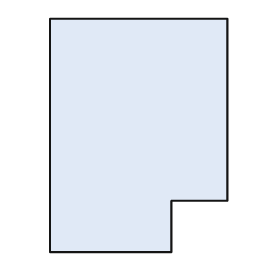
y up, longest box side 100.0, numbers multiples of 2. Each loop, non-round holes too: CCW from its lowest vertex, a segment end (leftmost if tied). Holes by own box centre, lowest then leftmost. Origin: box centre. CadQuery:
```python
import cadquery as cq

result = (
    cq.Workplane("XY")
    .moveTo(-38.0, -50.0)
    .lineTo(14.0, -50.0)
    .lineTo(14.0, -28.0)
    .lineTo(38.0, -28.0)
    .lineTo(38.0, 50.0)
    .lineTo(-38.0, 50.0)
    .close()
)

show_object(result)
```